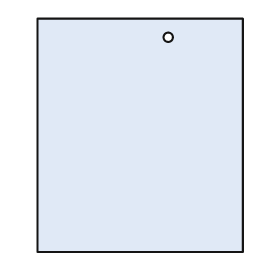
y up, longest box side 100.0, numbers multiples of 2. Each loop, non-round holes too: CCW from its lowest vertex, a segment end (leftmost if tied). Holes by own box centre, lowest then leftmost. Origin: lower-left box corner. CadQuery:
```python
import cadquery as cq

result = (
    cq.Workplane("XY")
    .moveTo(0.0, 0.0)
    .lineTo(88.0, 0.0)
    .lineTo(88.0, 100.0)
    .lineTo(0.0, 100.0)
    .close()
    .moveTo(56.0, 92.0)
    .circle(2.0)
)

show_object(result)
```